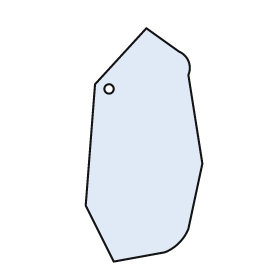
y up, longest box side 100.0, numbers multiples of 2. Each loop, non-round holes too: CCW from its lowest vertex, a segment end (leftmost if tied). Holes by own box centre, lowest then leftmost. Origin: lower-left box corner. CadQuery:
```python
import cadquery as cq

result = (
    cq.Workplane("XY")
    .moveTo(12.0, 0.0)
    .lineTo(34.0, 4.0)
    .threePointArc((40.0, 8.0), (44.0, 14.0))
    .lineTo(50.0, 42.0)
    .lineTo(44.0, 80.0)
    .threePointArc((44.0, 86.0), (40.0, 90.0))
    .lineTo(26.0, 100.0)
    .lineTo(4.0, 76.0)
    .lineTo(0.0, 24.0)
    .close()
    .moveTo(10.0, 74.0)
    .circle(2.0)
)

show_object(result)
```